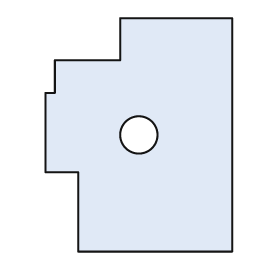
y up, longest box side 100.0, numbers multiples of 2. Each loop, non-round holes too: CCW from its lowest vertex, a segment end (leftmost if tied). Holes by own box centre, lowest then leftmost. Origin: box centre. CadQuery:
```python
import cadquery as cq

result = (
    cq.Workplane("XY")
    .moveTo(-26.0, -50.0)
    .lineTo(40.0, -50.0)
    .lineTo(40.0, 50.0)
    .lineTo(-8.0, 50.0)
    .lineTo(-8.0, 32.0)
    .lineTo(-36.0, 32.0)
    .lineTo(-36.0, 18.0)
    .lineTo(-40.0, 18.0)
    .lineTo(-40.0, -16.0)
    .lineTo(-26.0, -16.0)
    .close()
    .moveTo(0.0, 0.0)
    .circle(8.0)
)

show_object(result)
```